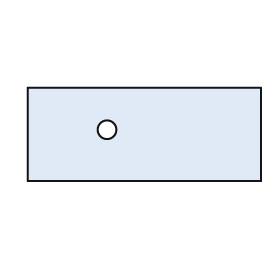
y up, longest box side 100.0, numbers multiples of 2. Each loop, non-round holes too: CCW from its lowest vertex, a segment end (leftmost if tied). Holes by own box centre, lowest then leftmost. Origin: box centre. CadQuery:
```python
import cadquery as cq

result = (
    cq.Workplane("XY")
    .moveTo(-50.0, -20.0)
    .lineTo(50.0, -20.0)
    .lineTo(50.0, 20.0)
    .lineTo(-50.0, 20.0)
    .close()
    .moveTo(-16.0, 2.0)
    .circle(4.0)
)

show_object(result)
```